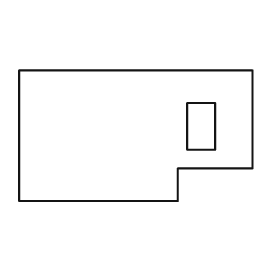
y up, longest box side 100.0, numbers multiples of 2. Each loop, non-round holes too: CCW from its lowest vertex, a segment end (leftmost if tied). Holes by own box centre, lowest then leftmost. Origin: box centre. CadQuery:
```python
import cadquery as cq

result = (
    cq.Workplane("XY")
    .moveTo(-50.0, -28.0)
    .lineTo(18.0, -28.0)
    .lineTo(18.0, -14.0)
    .lineTo(50.0, -14.0)
    .lineTo(50.0, 28.0)
    .lineTo(-50.0, 28.0)
    .close()
    .moveTo(22.0, -6.0)
    .lineTo(34.0, -6.0)
    .lineTo(34.0, 14.0)
    .lineTo(22.0, 14.0)
    .close()
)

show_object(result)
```